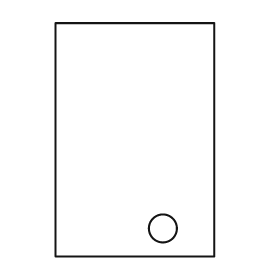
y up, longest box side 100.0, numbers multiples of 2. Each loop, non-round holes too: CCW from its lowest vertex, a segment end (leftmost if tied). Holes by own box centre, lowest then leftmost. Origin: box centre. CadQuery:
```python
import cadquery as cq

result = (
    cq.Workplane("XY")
    .moveTo(-34.0, -50.0)
    .lineTo(34.0, -50.0)
    .lineTo(34.0, 50.0)
    .lineTo(-34.0, 50.0)
    .close()
    .moveTo(12.0, -38.0)
    .circle(6.0)
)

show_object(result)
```